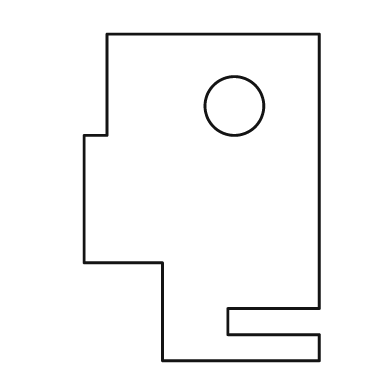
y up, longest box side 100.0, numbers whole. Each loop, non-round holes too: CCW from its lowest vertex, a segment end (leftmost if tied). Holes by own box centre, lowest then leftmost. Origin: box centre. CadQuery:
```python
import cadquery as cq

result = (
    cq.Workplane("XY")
    .moveTo(-12.0, -50.0)
    .lineTo(36.0, -50.0)
    .lineTo(36.0, -42.0)
    .lineTo(8.0, -42.0)
    .lineTo(8.0, -34.0)
    .lineTo(36.0, -34.0)
    .lineTo(36.0, 50.0)
    .lineTo(-29.0, 50.0)
    .lineTo(-29.0, 19.0)
    .lineTo(-36.0, 19.0)
    .lineTo(-36.0, -20.0)
    .lineTo(-12.0, -20.0)
    .close()
    .moveTo(10.0, 28.0)
    .circle(9.0)
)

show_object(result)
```